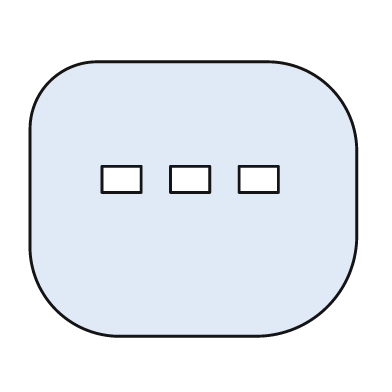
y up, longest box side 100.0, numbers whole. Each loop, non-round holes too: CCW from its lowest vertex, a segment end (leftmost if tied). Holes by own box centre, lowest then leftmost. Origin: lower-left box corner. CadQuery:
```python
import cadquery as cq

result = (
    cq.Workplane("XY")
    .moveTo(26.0, 0.0)
    .lineTo(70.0, 0.0)
    .threePointArc((91.0, 9.0), (100.0, 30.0))
    .lineTo(100.0, 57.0)
    .threePointArc((92.0, 76.0), (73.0, 84.0))
    .lineTo(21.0, 84.0)
    .threePointArc((6.0, 78.0), (0.0, 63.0))
    .lineTo(0.0, 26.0)
    .threePointArc((8.0, 8.0), (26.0, 0.0))
    .close()
    .moveTo(22.0, 44.0)
    .lineTo(34.0, 44.0)
    .lineTo(34.0, 52.0)
    .lineTo(22.0, 52.0)
    .close()
    .moveTo(43.0, 44.0)
    .lineTo(55.0, 44.0)
    .lineTo(55.0, 52.0)
    .lineTo(43.0, 52.0)
    .close()
    .moveTo(64.0, 44.0)
    .lineTo(76.0, 44.0)
    .lineTo(76.0, 52.0)
    .lineTo(64.0, 52.0)
    .close()
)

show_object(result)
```